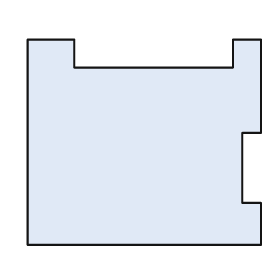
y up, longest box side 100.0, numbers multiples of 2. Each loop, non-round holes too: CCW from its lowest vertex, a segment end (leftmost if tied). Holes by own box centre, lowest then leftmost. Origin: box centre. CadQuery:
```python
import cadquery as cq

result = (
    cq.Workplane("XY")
    .moveTo(-50.0, -44.0)
    .lineTo(50.0, -44.0)
    .lineTo(50.0, -26.0)
    .lineTo(42.0, -26.0)
    .lineTo(42.0, 4.0)
    .lineTo(50.0, 4.0)
    .lineTo(50.0, 44.0)
    .lineTo(38.0, 44.0)
    .lineTo(38.0, 32.0)
    .lineTo(-30.0, 32.0)
    .lineTo(-30.0, 44.0)
    .lineTo(-50.0, 44.0)
    .close()
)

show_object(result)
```